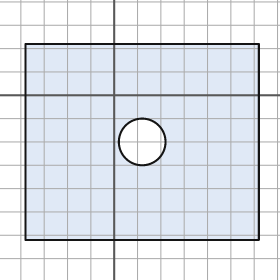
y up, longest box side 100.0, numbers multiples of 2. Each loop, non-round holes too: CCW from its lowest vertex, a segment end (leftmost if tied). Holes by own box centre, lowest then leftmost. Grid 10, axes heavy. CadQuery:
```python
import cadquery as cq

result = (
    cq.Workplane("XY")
    .moveTo(-38.0, -62.0)
    .lineTo(62.0, -62.0)
    .lineTo(62.0, 22.0)
    .lineTo(-38.0, 22.0)
    .close()
    .moveTo(12.0, -20.0)
    .circle(10.0)
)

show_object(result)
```